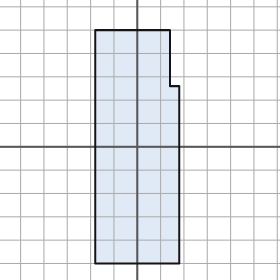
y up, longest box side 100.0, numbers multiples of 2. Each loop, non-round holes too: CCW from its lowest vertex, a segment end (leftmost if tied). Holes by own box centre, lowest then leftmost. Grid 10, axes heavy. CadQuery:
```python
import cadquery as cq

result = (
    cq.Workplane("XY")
    .moveTo(-18.0, -50.0)
    .lineTo(18.0, -50.0)
    .lineTo(18.0, 26.0)
    .lineTo(14.0, 26.0)
    .lineTo(14.0, 50.0)
    .lineTo(-18.0, 50.0)
    .close()
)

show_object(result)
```